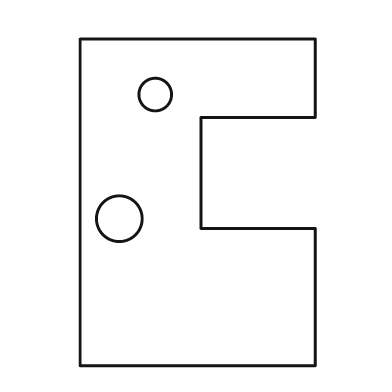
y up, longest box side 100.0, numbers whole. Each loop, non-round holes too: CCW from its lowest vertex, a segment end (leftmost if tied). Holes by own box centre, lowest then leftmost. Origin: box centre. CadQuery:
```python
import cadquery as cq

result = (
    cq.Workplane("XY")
    .moveTo(-36.0, -50.0)
    .lineTo(36.0, -50.0)
    .lineTo(36.0, -8.0)
    .lineTo(1.0, -8.0)
    .lineTo(1.0, 26.0)
    .lineTo(36.0, 26.0)
    .lineTo(36.0, 50.0)
    .lineTo(-36.0, 50.0)
    .close()
    .moveTo(-24.0, -5.0)
    .circle(7.0)
    .moveTo(-13.0, 33.0)
    .circle(5.0)
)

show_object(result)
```